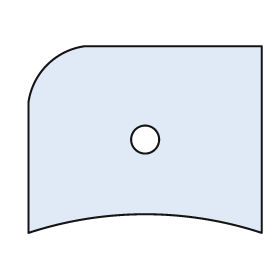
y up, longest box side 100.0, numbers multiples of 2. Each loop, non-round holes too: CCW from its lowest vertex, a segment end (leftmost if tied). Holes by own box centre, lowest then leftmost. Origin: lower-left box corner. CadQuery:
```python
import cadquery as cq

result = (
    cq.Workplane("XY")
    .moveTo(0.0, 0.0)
    .threePointArc((50.0, 8.0), (100.0, 0.0))
    .lineTo(100.0, 80.0)
    .lineTo(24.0, 80.0)
    .threePointArc((8.0, 72.0), (0.0, 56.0))
    .close()
    .moveTo(50.0, 40.0)
    .circle(6.0)
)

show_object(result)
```